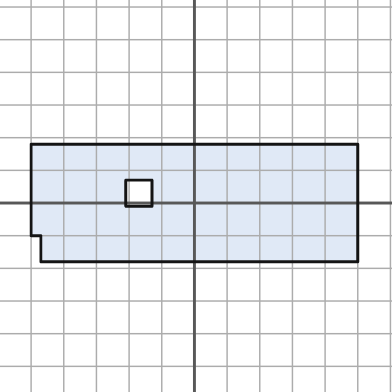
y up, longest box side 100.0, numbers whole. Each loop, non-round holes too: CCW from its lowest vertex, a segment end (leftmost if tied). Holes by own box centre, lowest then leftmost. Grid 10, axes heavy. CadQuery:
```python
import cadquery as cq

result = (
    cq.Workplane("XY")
    .moveTo(-47.0, -18.0)
    .lineTo(50.0, -18.0)
    .lineTo(50.0, 18.0)
    .lineTo(-50.0, 18.0)
    .lineTo(-50.0, -10.0)
    .lineTo(-47.0, -10.0)
    .close()
    .moveTo(-21.0, -1.0)
    .lineTo(-13.0, -1.0)
    .lineTo(-13.0, 7.0)
    .lineTo(-21.0, 7.0)
    .close()
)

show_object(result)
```